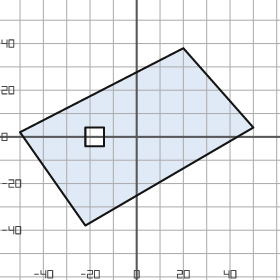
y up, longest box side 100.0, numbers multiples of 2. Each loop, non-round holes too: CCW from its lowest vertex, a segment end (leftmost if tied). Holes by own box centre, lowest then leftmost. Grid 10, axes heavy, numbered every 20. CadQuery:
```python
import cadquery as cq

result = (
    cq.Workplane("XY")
    .moveTo(-22.0, -38.0)
    .lineTo(50.0, 4.0)
    .lineTo(20.0, 38.0)
    .lineTo(-50.0, 2.0)
    .close()
    .moveTo(-22.0, -4.0)
    .lineTo(-14.0, -4.0)
    .lineTo(-14.0, 4.0)
    .lineTo(-22.0, 4.0)
    .close()
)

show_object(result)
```